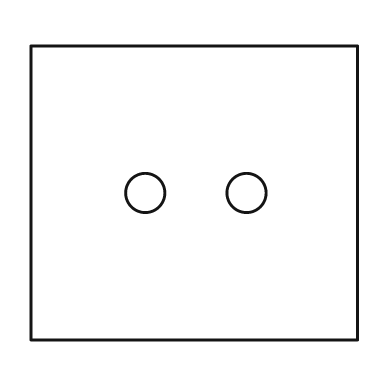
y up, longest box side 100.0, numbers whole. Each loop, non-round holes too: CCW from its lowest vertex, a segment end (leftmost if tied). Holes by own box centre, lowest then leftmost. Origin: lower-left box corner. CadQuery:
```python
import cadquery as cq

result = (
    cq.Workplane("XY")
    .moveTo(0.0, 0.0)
    .lineTo(100.0, 0.0)
    .lineTo(100.0, 90.0)
    .lineTo(0.0, 90.0)
    .close()
    .moveTo(35.0, 45.0)
    .circle(6.0)
    .moveTo(66.0, 45.0)
    .circle(6.0)
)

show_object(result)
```